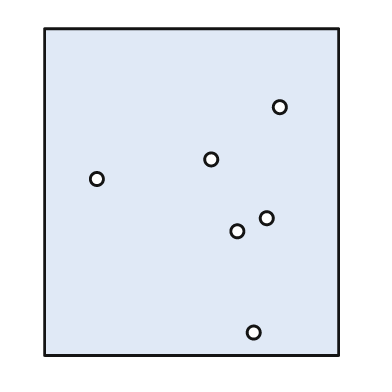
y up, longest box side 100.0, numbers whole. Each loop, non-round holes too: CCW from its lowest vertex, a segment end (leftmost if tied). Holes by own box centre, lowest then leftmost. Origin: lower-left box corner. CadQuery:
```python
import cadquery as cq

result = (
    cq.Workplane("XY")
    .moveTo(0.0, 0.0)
    .lineTo(90.0, 0.0)
    .lineTo(90.0, 100.0)
    .lineTo(0.0, 100.0)
    .close()
    .moveTo(64.0, 7.0)
    .circle(2.0)
    .moveTo(59.0, 38.0)
    .circle(2.0)
    .moveTo(68.0, 42.0)
    .circle(2.0)
    .moveTo(16.0, 54.0)
    .circle(2.0)
    .moveTo(51.0, 60.0)
    .circle(2.0)
    .moveTo(72.0, 76.0)
    .circle(2.0)
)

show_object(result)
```